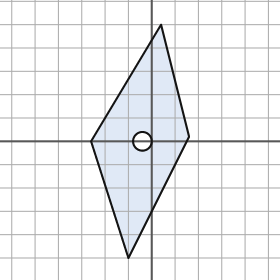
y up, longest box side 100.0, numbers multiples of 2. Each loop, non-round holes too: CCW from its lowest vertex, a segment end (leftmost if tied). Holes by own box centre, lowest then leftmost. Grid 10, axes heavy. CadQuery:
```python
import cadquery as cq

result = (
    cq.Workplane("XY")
    .moveTo(-10.0, -50.0)
    .lineTo(16.0, 2.0)
    .lineTo(4.0, 50.0)
    .lineTo(-26.0, 0.0)
    .close()
    .moveTo(-4.0, 0.0)
    .circle(4.0)
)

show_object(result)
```